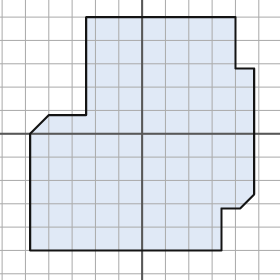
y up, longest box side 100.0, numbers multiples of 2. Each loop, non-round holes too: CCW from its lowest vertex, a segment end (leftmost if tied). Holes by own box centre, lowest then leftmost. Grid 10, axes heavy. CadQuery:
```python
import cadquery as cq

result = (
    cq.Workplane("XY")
    .moveTo(-48.0, -50.0)
    .lineTo(34.0, -50.0)
    .lineTo(34.0, -32.0)
    .lineTo(42.0, -32.0)
    .lineTo(48.0, -26.0)
    .lineTo(48.0, 28.0)
    .lineTo(40.0, 28.0)
    .lineTo(40.0, 50.0)
    .lineTo(-24.0, 50.0)
    .lineTo(-24.0, 8.0)
    .lineTo(-40.0, 8.0)
    .lineTo(-48.0, 0.0)
    .close()
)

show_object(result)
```